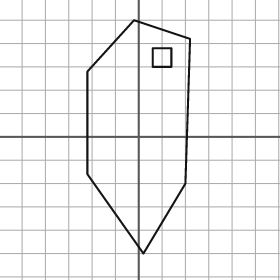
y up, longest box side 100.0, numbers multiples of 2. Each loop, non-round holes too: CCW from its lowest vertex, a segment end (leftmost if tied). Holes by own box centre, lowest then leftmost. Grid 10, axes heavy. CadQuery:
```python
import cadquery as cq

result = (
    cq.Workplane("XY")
    .moveTo(2.0, -50.0)
    .lineTo(20.0, -20.0)
    .lineTo(22.0, 42.0)
    .lineTo(-2.0, 50.0)
    .lineTo(-22.0, 28.0)
    .lineTo(-22.0, -16.0)
    .close()
    .moveTo(6.0, 30.0)
    .lineTo(14.0, 30.0)
    .lineTo(14.0, 38.0)
    .lineTo(6.0, 38.0)
    .close()
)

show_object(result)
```